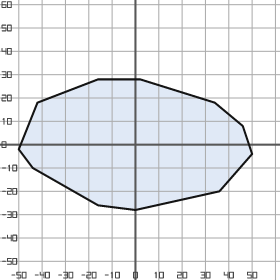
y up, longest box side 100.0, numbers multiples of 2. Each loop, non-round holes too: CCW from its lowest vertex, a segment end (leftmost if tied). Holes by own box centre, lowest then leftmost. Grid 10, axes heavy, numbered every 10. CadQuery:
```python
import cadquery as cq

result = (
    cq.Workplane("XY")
    .moveTo(0.0, -28.0)
    .lineTo(36.0, -20.0)
    .lineTo(50.0, -4.0)
    .lineTo(46.0, 8.0)
    .lineTo(34.0, 18.0)
    .lineTo(2.0, 28.0)
    .lineTo(-16.0, 28.0)
    .lineTo(-42.0, 18.0)
    .lineTo(-50.0, -2.0)
    .lineTo(-44.0, -10.0)
    .lineTo(-16.0, -26.0)
    .close()
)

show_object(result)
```